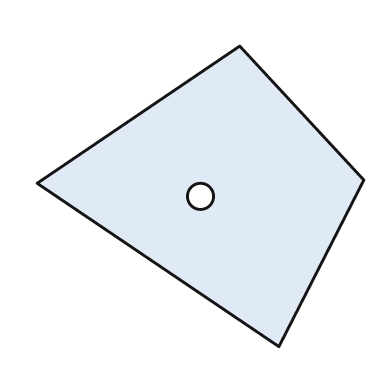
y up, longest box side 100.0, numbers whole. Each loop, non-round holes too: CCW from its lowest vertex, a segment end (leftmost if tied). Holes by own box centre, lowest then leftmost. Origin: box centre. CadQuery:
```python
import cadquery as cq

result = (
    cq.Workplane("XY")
    .moveTo(24.0, -46.0)
    .lineTo(50.0, 5.0)
    .lineTo(12.0, 46.0)
    .lineTo(-50.0, 4.0)
    .close()
    .moveTo(0.0, 0.0)
    .circle(4.0)
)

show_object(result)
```